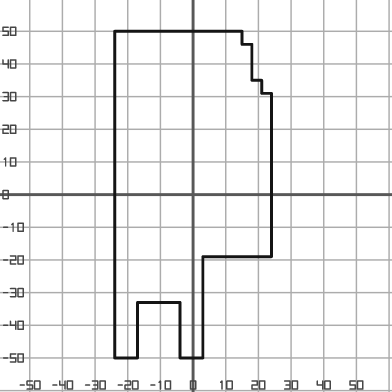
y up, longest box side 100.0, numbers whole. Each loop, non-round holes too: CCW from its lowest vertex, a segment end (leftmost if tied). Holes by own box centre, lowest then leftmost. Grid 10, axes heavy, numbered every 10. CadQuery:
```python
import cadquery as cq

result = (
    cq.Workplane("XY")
    .moveTo(-24.0, -50.0)
    .lineTo(-17.0, -50.0)
    .lineTo(-17.0, -33.0)
    .lineTo(-4.0, -33.0)
    .lineTo(-4.0, -50.0)
    .lineTo(3.0, -50.0)
    .lineTo(3.0, -19.0)
    .lineTo(24.0, -19.0)
    .lineTo(24.0, 31.0)
    .lineTo(21.0, 31.0)
    .lineTo(21.0, 35.0)
    .lineTo(18.0, 35.0)
    .lineTo(18.0, 46.0)
    .lineTo(15.0, 46.0)
    .lineTo(15.0, 50.0)
    .lineTo(-24.0, 50.0)
    .close()
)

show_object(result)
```